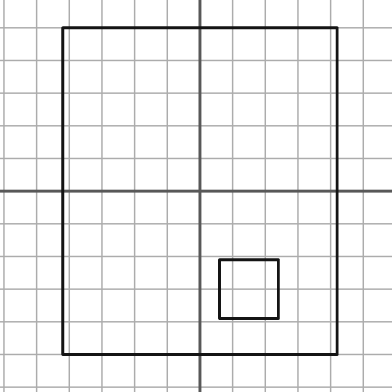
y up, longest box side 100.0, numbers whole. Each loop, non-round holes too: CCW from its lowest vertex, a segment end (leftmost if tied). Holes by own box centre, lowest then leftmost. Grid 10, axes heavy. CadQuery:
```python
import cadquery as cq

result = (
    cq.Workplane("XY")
    .moveTo(-42.0, -50.0)
    .lineTo(42.0, -50.0)
    .lineTo(42.0, 50.0)
    .lineTo(-42.0, 50.0)
    .close()
    .moveTo(6.0, -39.0)
    .lineTo(24.0, -39.0)
    .lineTo(24.0, -21.0)
    .lineTo(6.0, -21.0)
    .close()
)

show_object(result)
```